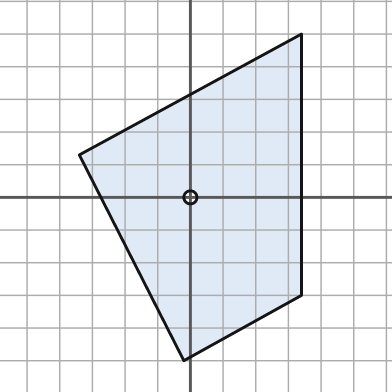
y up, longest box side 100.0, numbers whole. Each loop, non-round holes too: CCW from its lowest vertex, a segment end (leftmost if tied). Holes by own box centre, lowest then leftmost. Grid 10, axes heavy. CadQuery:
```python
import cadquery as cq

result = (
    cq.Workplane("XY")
    .moveTo(-2.0, -50.0)
    .lineTo(34.0, -30.0)
    .lineTo(34.0, 50.0)
    .lineTo(-34.0, 13.0)
    .close()
    .moveTo(0.0, 0.0)
    .circle(2.0)
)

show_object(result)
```